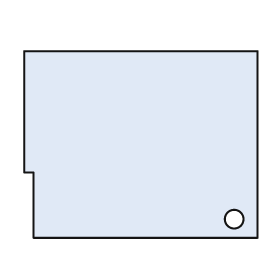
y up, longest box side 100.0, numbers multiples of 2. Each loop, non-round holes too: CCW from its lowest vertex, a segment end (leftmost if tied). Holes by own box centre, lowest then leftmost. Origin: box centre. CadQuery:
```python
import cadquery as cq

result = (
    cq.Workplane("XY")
    .moveTo(-46.0, -40.0)
    .lineTo(50.0, -40.0)
    .lineTo(50.0, 40.0)
    .lineTo(-50.0, 40.0)
    .lineTo(-50.0, -12.0)
    .lineTo(-46.0, -12.0)
    .close()
    .moveTo(40.0, -32.0)
    .circle(4.0)
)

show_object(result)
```